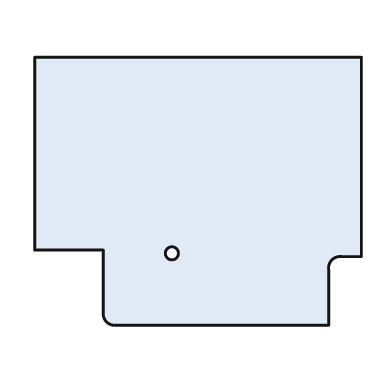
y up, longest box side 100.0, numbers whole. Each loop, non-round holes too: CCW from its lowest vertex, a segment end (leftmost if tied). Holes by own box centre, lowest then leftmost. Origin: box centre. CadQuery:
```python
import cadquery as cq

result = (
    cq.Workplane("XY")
    .moveTo(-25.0, -41.0)
    .lineTo(40.0, -41.0)
    .lineTo(40.0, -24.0)
    .threePointArc((41.0, -21.0), (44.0, -20.0))
    .lineTo(50.0, -20.0)
    .lineTo(50.0, 41.0)
    .lineTo(-50.0, 41.0)
    .lineTo(-50.0, -18.0)
    .lineTo(-29.0, -18.0)
    .lineTo(-29.0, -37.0)
    .threePointArc((-28.0, -40.0), (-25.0, -41.0))
    .close()
    .moveTo(-8.0, -19.0)
    .circle(2.0)
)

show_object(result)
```